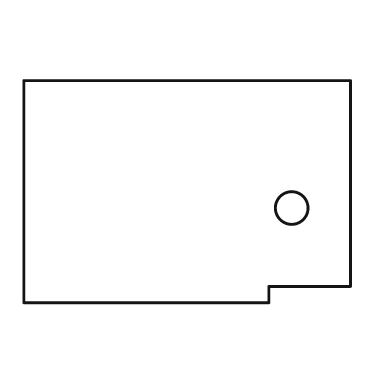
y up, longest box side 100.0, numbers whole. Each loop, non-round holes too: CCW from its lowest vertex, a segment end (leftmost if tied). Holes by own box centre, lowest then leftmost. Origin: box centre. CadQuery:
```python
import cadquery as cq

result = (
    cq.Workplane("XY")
    .moveTo(-50.0, -34.0)
    .lineTo(25.0, -34.0)
    .lineTo(25.0, -29.0)
    .lineTo(50.0, -29.0)
    .lineTo(50.0, 34.0)
    .lineTo(-50.0, 34.0)
    .close()
    .moveTo(32.0, -5.0)
    .circle(5.0)
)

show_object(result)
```